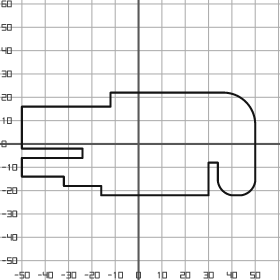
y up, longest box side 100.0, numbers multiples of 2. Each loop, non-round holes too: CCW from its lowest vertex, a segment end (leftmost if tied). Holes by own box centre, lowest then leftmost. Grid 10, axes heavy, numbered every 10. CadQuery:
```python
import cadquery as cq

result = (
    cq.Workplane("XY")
    .moveTo(-16.0, -22.0)
    .lineTo(30.0, -22.0)
    .lineTo(30.0, -8.0)
    .lineTo(34.0, -8.0)
    .lineTo(34.0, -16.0)
    .threePointArc((36.0, -20.0), (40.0, -22.0))
    .lineTo(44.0, -22.0)
    .threePointArc((48.0, -20.0), (50.0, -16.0))
    .lineTo(50.0, 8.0)
    .threePointArc((46.0, 18.0), (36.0, 22.0))
    .lineTo(-12.0, 22.0)
    .lineTo(-12.0, 16.0)
    .lineTo(-50.0, 16.0)
    .lineTo(-50.0, -2.0)
    .lineTo(-24.0, -2.0)
    .lineTo(-24.0, -6.0)
    .lineTo(-50.0, -6.0)
    .lineTo(-50.0, -14.0)
    .lineTo(-32.0, -14.0)
    .lineTo(-32.0, -18.0)
    .lineTo(-16.0, -18.0)
    .close()
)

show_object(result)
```